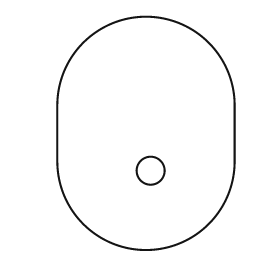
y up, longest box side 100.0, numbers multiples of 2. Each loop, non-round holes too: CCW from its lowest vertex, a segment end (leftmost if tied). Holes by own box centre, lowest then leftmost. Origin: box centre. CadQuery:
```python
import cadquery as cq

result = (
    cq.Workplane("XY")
    .moveTo(-38.0, -12.0)
    .threePointArc((0.0, -50.0), (38.0, -12.0))
    .lineTo(38.0, 12.0)
    .threePointArc((0.0, 50.0), (-38.0, 12.0))
    .close()
    .moveTo(2.0, -16.0)
    .circle(6.0)
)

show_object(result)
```